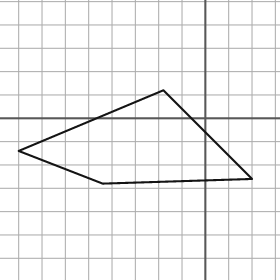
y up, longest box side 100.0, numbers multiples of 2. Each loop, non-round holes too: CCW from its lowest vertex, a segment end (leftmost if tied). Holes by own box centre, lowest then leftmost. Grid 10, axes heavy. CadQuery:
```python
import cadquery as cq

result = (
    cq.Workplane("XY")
    .moveTo(-44.0, -28.0)
    .lineTo(20.0, -26.0)
    .lineTo(-18.0, 12.0)
    .lineTo(-80.0, -14.0)
    .close()
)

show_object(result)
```